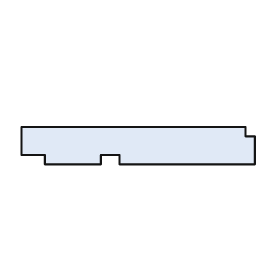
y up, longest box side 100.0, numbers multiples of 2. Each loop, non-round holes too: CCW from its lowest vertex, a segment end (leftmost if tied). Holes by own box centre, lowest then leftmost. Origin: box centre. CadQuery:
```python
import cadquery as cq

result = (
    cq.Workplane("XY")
    .moveTo(-40.0, -8.0)
    .lineTo(-16.0, -8.0)
    .lineTo(-16.0, -4.0)
    .lineTo(-8.0, -4.0)
    .lineTo(-8.0, -8.0)
    .lineTo(50.0, -8.0)
    .lineTo(50.0, 4.0)
    .lineTo(46.0, 4.0)
    .lineTo(46.0, 8.0)
    .lineTo(-50.0, 8.0)
    .lineTo(-50.0, -4.0)
    .lineTo(-40.0, -4.0)
    .close()
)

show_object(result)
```